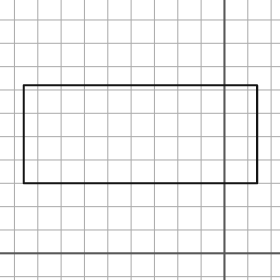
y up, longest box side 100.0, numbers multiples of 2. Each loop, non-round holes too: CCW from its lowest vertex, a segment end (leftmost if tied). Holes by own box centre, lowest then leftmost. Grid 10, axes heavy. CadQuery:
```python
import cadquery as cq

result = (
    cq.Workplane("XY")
    .moveTo(-86.0, 30.0)
    .lineTo(14.0, 30.0)
    .lineTo(14.0, 72.0)
    .lineTo(-86.0, 72.0)
    .close()
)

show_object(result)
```